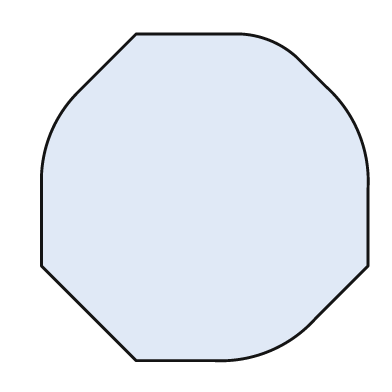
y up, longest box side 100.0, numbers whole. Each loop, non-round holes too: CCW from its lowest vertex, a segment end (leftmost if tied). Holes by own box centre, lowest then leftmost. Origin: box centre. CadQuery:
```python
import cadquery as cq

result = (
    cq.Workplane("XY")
    .moveTo(-21.0, -50.0)
    .lineTo(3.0, -50.0)
    .threePointArc((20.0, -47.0), (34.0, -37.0))
    .lineTo(50.0, -21.0)
    .lineTo(50.0, 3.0)
    .threePointArc((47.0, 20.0), (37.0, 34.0))
    .lineTo(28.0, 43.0)
    .threePointArc((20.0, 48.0), (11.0, 50.0))
    .lineTo(-21.0, 50.0)
    .lineTo(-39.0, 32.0)
    .threePointArc((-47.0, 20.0), (-50.0, 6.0))
    .lineTo(-50.0, -21.0)
    .close()
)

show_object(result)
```